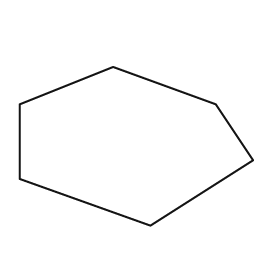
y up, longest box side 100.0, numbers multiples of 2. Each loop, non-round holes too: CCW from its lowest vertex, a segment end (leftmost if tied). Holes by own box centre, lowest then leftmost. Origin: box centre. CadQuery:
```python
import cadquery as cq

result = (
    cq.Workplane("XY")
    .moveTo(6.0, -34.0)
    .lineTo(50.0, -6.0)
    .lineTo(34.0, 18.0)
    .lineTo(-10.0, 34.0)
    .lineTo(-50.0, 18.0)
    .lineTo(-50.0, -14.0)
    .close()
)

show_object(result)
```